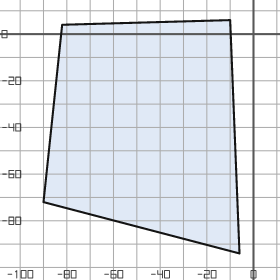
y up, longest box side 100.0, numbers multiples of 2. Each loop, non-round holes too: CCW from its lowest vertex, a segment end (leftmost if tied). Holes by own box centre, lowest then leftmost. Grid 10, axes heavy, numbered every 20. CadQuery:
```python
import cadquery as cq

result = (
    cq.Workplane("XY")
    .moveTo(-6.0, -94.0)
    .lineTo(-10.0, 6.0)
    .lineTo(-82.0, 4.0)
    .lineTo(-90.0, -72.0)
    .close()
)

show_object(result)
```